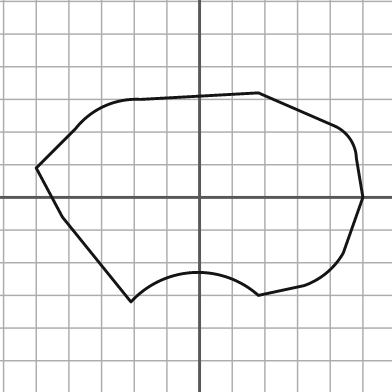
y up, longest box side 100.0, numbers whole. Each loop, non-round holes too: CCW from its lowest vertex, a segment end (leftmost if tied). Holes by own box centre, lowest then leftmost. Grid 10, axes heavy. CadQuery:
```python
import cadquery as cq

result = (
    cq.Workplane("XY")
    .moveTo(-21.0, -32.0)
    .threePointArc((-2.0, -23.0), (18.0, -30.0))
    .lineTo(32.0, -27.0)
    .threePointArc((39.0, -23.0), (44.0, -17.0))
    .lineTo(50.0, 0.0)
    .lineTo(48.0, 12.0)
    .threePointArc((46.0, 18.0), (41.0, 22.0))
    .lineTo(18.0, 32.0)
    .lineTo(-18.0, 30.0)
    .threePointArc((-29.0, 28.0), (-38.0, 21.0))
    .lineTo(-50.0, 9.0)
    .lineTo(-42.0, -6.0)
    .close()
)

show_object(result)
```